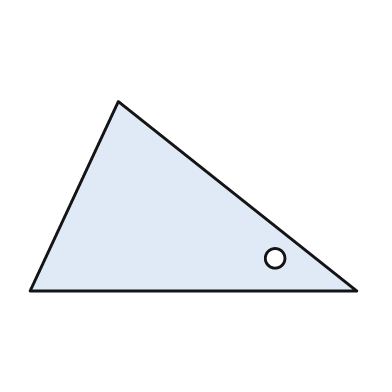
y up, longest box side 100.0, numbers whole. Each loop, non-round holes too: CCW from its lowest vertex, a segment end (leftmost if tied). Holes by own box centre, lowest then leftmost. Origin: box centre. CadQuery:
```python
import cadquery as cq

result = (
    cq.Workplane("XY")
    .moveTo(-50.0, -29.0)
    .lineTo(50.0, -29.0)
    .lineTo(-23.0, 29.0)
    .close()
    .moveTo(25.0, -19.0)
    .circle(3.0)
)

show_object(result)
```